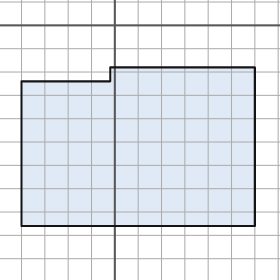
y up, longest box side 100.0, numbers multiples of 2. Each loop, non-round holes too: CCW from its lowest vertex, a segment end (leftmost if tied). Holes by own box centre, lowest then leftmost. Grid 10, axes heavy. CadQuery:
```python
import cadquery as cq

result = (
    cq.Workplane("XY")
    .moveTo(-40.0, -86.0)
    .lineTo(60.0, -86.0)
    .lineTo(60.0, -18.0)
    .lineTo(-2.0, -18.0)
    .lineTo(-2.0, -24.0)
    .lineTo(-40.0, -24.0)
    .close()
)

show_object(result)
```